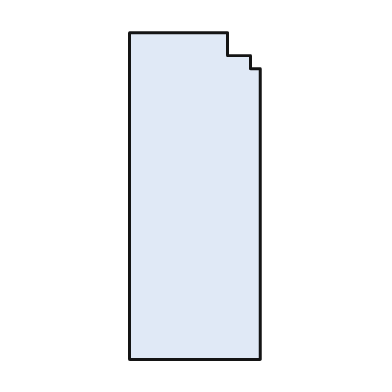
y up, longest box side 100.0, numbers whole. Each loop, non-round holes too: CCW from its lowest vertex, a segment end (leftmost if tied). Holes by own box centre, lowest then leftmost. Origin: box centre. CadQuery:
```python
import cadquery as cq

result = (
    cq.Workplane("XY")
    .moveTo(-20.0, -50.0)
    .lineTo(20.0, -50.0)
    .lineTo(20.0, 39.0)
    .lineTo(17.0, 39.0)
    .lineTo(17.0, 43.0)
    .lineTo(10.0, 43.0)
    .lineTo(10.0, 50.0)
    .lineTo(-20.0, 50.0)
    .close()
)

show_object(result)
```